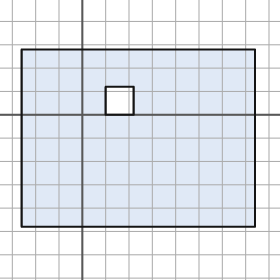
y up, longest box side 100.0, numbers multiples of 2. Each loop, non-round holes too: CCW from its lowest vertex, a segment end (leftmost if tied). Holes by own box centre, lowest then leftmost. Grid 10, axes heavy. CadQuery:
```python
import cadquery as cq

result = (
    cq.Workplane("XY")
    .moveTo(-26.0, -48.0)
    .lineTo(74.0, -48.0)
    .lineTo(74.0, 28.0)
    .lineTo(-26.0, 28.0)
    .close()
    .moveTo(10.0, 0.0)
    .lineTo(22.0, 0.0)
    .lineTo(22.0, 12.0)
    .lineTo(10.0, 12.0)
    .close()
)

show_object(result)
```